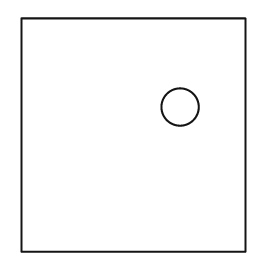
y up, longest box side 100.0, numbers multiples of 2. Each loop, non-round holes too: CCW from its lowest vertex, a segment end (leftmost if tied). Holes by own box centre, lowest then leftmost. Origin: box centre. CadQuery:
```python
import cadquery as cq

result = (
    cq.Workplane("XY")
    .moveTo(-48.0, -50.0)
    .lineTo(48.0, -50.0)
    .lineTo(48.0, 50.0)
    .lineTo(-48.0, 50.0)
    .close()
    .moveTo(20.0, 12.0)
    .circle(8.0)
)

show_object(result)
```